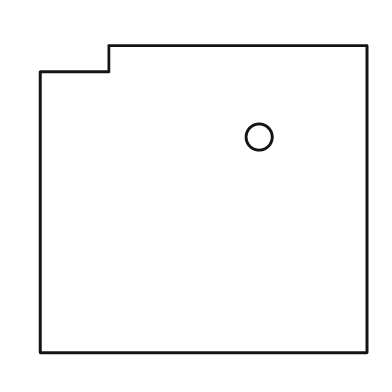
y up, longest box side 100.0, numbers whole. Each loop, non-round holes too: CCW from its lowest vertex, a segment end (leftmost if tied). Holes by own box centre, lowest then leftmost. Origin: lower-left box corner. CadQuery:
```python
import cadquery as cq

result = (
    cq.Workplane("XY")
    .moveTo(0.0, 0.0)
    .lineTo(100.0, 0.0)
    .lineTo(100.0, 94.0)
    .lineTo(21.0, 94.0)
    .lineTo(21.0, 86.0)
    .lineTo(0.0, 86.0)
    .close()
    .moveTo(67.0, 66.0)
    .circle(4.0)
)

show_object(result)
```